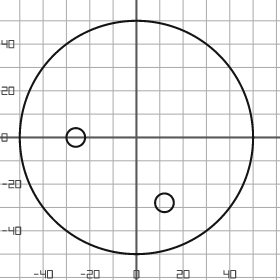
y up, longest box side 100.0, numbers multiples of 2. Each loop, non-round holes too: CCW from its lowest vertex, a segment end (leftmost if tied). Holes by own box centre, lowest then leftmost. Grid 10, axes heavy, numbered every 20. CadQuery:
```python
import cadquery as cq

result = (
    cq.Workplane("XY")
    .moveTo(0.0, 0.0)
    .circle(50.0)
    .moveTo(12.0, -28.0)
    .circle(4.0)
    .moveTo(-26.0, 0.0)
    .circle(4.0)
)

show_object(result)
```